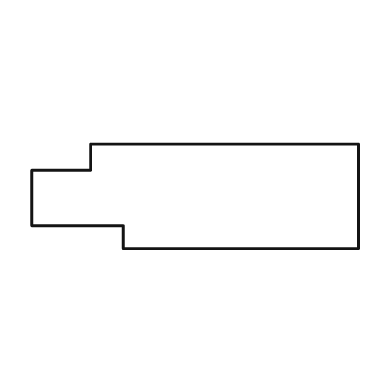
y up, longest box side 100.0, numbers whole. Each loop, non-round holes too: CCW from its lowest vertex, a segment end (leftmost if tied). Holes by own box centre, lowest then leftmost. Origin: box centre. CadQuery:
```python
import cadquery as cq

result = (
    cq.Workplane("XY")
    .moveTo(-22.0, -16.0)
    .lineTo(50.0, -16.0)
    .lineTo(50.0, 16.0)
    .lineTo(-32.0, 16.0)
    .lineTo(-32.0, 8.0)
    .lineTo(-50.0, 8.0)
    .lineTo(-50.0, -9.0)
    .lineTo(-22.0, -9.0)
    .close()
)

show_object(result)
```